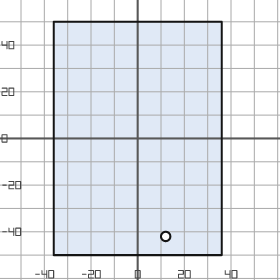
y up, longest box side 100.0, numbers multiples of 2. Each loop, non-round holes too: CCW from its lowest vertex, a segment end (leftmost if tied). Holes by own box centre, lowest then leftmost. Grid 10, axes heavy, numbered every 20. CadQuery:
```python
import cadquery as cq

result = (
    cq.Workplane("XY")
    .moveTo(-36.0, -50.0)
    .lineTo(36.0, -50.0)
    .lineTo(36.0, 50.0)
    .lineTo(-36.0, 50.0)
    .close()
    .moveTo(12.0, -42.0)
    .circle(2.0)
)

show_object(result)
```